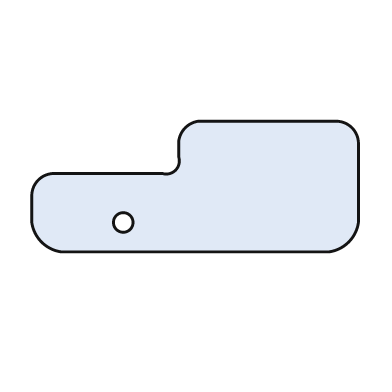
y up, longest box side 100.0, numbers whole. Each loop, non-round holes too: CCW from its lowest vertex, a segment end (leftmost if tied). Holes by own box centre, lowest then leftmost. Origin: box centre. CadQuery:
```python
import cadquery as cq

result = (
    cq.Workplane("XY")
    .moveTo(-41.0, -20.0)
    .lineTo(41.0, -20.0)
    .threePointArc((47.0, -17.0), (50.0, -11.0))
    .lineTo(50.0, 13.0)
    .threePointArc((48.0, 18.0), (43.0, 20.0))
    .lineTo(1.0, 20.0)
    .threePointArc((-3.0, 18.0), (-5.0, 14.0))
    .lineTo(-5.0, 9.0)
    .threePointArc((-6.0, 5.0), (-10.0, 4.0))
    .lineTo(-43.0, 4.0)
    .threePointArc((-48.0, 2.0), (-50.0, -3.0))
    .lineTo(-50.0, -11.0)
    .threePointArc((-47.0, -17.0), (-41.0, -20.0))
    .close()
    .moveTo(-22.0, -11.0)
    .circle(3.0)
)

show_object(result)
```